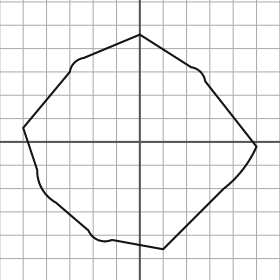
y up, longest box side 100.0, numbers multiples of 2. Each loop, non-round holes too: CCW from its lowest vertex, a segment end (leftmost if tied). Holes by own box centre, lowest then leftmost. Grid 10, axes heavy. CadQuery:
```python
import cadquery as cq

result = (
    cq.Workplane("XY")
    .moveTo(10.0, -46.0)
    .lineTo(36.0, -20.0)
    .threePointArc((44.0, -12.0), (50.0, -2.0))
    .lineTo(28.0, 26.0)
    .threePointArc((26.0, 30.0), (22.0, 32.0))
    .lineTo(0.0, 46.0)
    .lineTo(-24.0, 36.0)
    .threePointArc((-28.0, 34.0), (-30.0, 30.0))
    .lineTo(-50.0, 6.0)
    .lineTo(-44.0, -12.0)
    .threePointArc((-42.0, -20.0), (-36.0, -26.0))
    .lineTo(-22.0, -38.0)
    .threePointArc((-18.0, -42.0), (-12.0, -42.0))
    .close()
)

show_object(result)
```